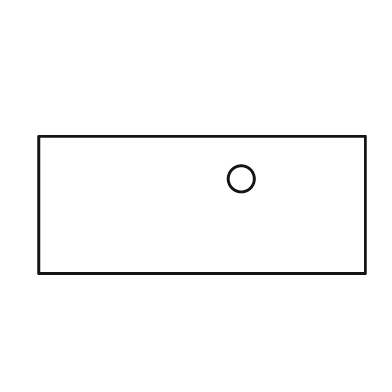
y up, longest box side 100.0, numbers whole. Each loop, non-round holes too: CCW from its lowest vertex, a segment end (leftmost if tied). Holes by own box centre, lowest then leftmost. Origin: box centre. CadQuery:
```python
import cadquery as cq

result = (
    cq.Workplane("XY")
    .moveTo(-50.0, -21.0)
    .lineTo(50.0, -21.0)
    .lineTo(50.0, 21.0)
    .lineTo(-50.0, 21.0)
    .close()
    .moveTo(12.0, 8.0)
    .circle(4.0)
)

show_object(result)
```